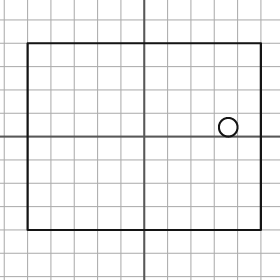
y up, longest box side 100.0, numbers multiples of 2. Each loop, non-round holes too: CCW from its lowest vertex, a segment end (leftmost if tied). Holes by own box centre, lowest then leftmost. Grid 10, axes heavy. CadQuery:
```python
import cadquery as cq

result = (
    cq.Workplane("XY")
    .moveTo(-50.0, -40.0)
    .lineTo(50.0, -40.0)
    .lineTo(50.0, 40.0)
    .lineTo(-50.0, 40.0)
    .close()
    .moveTo(36.0, 4.0)
    .circle(4.0)
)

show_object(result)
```